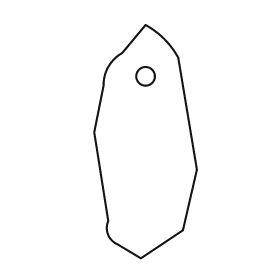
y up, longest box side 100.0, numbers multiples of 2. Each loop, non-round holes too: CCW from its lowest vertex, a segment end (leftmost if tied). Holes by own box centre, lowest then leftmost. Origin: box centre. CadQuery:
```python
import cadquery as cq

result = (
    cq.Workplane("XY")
    .moveTo(-2.0, -50.0)
    .lineTo(16.0, -38.0)
    .lineTo(22.0, -12.0)
    .lineTo(14.0, 36.0)
    .threePointArc((8.0, 44.0), (0.0, 50.0))
    .lineTo(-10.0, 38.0)
    .threePointArc((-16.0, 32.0), (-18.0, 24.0))
    .lineTo(-22.0, 4.0)
    .lineTo(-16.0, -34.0)
    .threePointArc((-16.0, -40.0), (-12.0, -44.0))
    .close()
    .moveTo(0.0, 28.0)
    .circle(4.0)
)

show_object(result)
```